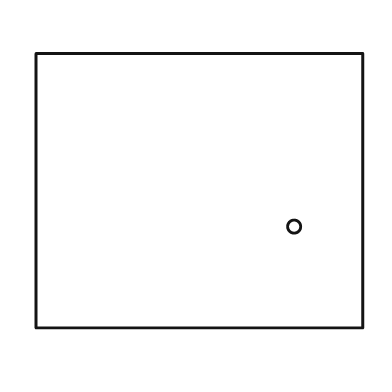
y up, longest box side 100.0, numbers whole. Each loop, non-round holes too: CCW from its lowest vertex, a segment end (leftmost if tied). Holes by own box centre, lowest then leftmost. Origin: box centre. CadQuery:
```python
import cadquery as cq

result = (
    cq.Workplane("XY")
    .moveTo(-50.0, -42.0)
    .lineTo(50.0, -42.0)
    .lineTo(50.0, 42.0)
    .lineTo(-50.0, 42.0)
    .close()
    .moveTo(29.0, -11.0)
    .circle(2.0)
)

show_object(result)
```